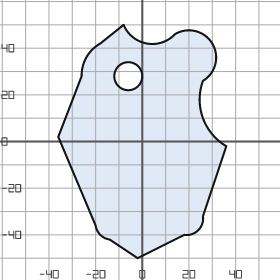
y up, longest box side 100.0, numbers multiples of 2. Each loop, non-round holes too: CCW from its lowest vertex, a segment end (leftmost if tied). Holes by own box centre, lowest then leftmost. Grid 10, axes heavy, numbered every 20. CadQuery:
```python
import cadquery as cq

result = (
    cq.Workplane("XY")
    .moveTo(-2.0, -50.0)
    .lineTo(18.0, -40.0)
    .threePointArc((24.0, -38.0), (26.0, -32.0))
    .lineTo(36.0, -2.0)
    .threePointArc((26.0, 10.0), (26.0, 26.0))
    .threePointArc((30.0, 42.0), (14.0, 46.0))
    .threePointArc((2.0, 42.0), (-8.0, 50.0))
    .lineTo(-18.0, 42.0)
    .threePointArc((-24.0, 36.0), (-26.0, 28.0))
    .lineTo(-36.0, 2.0)
    .lineTo(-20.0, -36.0)
    .threePointArc((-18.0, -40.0), (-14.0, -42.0))
    .close()
    .moveTo(-6.0, 28.0)
    .circle(6.0)
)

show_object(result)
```